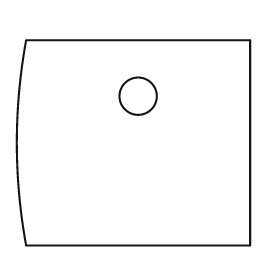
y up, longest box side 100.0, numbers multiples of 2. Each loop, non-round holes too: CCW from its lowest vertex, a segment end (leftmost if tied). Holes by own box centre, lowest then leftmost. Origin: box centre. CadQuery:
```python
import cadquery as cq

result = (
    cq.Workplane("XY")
    .moveTo(-46.0, -44.0)
    .lineTo(50.0, -44.0)
    .lineTo(50.0, 44.0)
    .lineTo(-46.0, 44.0)
    .threePointArc((-50.0, 0.0), (-46.0, -44.0))
    .close()
    .moveTo(2.0, 20.0)
    .circle(8.0)
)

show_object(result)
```